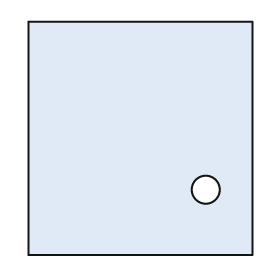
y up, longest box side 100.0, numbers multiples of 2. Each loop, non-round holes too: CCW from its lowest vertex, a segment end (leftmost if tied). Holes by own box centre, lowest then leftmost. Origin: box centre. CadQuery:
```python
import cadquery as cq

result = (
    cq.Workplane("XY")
    .moveTo(-48.0, -50.0)
    .lineTo(48.0, -50.0)
    .lineTo(48.0, 50.0)
    .lineTo(-48.0, 50.0)
    .close()
    .moveTo(28.0, -22.0)
    .circle(6.0)
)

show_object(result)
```